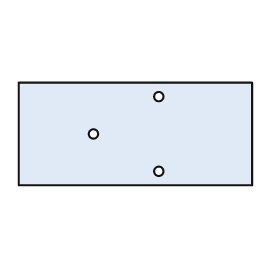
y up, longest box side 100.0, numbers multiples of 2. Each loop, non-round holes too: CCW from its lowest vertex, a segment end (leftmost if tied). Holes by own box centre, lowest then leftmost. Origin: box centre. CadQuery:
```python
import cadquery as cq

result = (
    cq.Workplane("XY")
    .moveTo(-50.0, -22.0)
    .lineTo(50.0, -22.0)
    .lineTo(50.0, 22.0)
    .lineTo(-50.0, 22.0)
    .close()
    .moveTo(10.0, -16.0)
    .circle(2.0)
    .moveTo(-18.0, 0.0)
    .circle(2.0)
    .moveTo(10.0, 16.0)
    .circle(2.0)
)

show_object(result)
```